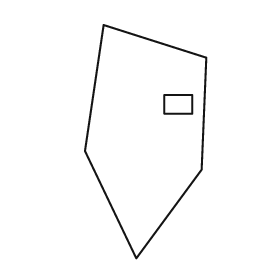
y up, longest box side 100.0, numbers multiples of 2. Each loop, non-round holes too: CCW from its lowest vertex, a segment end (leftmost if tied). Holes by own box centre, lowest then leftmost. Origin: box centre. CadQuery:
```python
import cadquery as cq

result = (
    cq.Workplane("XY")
    .moveTo(-4.0, -50.0)
    .lineTo(24.0, -12.0)
    .lineTo(26.0, 36.0)
    .lineTo(-18.0, 50.0)
    .lineTo(-26.0, -4.0)
    .close()
    .moveTo(8.0, 12.0)
    .lineTo(20.0, 12.0)
    .lineTo(20.0, 20.0)
    .lineTo(8.0, 20.0)
    .close()
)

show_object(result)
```